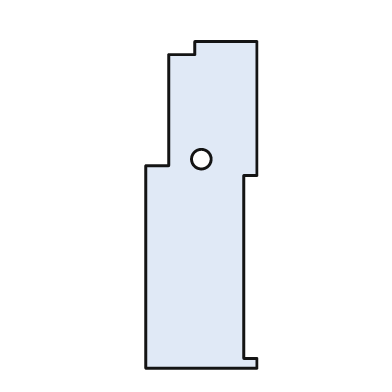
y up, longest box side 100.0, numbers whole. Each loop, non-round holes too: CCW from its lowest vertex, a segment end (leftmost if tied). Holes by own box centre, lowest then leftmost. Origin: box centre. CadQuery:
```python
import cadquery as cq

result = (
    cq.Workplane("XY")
    .moveTo(-17.0, -50.0)
    .lineTo(17.0, -50.0)
    .lineTo(17.0, -47.0)
    .lineTo(13.0, -47.0)
    .lineTo(13.0, 9.0)
    .lineTo(17.0, 9.0)
    .lineTo(17.0, 50.0)
    .lineTo(-2.0, 50.0)
    .lineTo(-2.0, 46.0)
    .lineTo(-10.0, 46.0)
    .lineTo(-10.0, 12.0)
    .lineTo(-17.0, 12.0)
    .close()
    .moveTo(0.0, 14.0)
    .circle(3.0)
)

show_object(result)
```